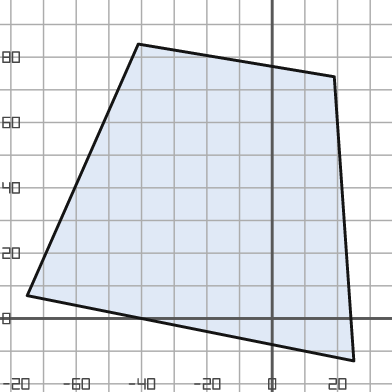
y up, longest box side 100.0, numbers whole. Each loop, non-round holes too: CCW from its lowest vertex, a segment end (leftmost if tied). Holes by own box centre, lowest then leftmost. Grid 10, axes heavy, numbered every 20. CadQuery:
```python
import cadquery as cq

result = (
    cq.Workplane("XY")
    .moveTo(25.0, -13.0)
    .lineTo(19.0, 74.0)
    .lineTo(-41.0, 84.0)
    .lineTo(-75.0, 7.0)
    .close()
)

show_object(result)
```